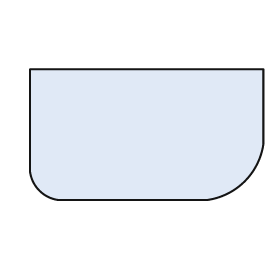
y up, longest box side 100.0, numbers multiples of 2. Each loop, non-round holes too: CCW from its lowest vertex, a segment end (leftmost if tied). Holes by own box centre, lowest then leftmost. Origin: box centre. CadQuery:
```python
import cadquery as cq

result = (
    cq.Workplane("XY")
    .moveTo(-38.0, -28.0)
    .lineTo(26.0, -28.0)
    .threePointArc((42.0, -20.0), (50.0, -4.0))
    .lineTo(50.0, 28.0)
    .lineTo(-50.0, 28.0)
    .lineTo(-50.0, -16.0)
    .threePointArc((-46.0, -24.0), (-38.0, -28.0))
    .close()
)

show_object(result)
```